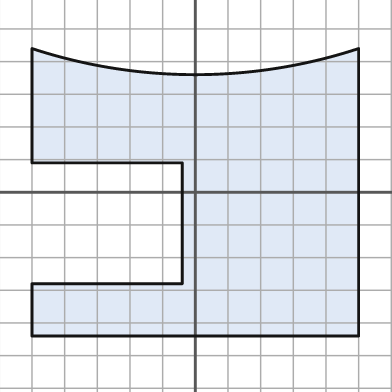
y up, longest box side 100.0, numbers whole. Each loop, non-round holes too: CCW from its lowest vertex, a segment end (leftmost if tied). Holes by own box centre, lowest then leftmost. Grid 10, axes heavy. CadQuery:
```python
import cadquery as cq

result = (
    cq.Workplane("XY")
    .moveTo(-50.0, -44.0)
    .lineTo(50.0, -44.0)
    .lineTo(50.0, 44.0)
    .threePointArc((0.0, 36.0), (-50.0, 44.0))
    .lineTo(-50.0, 9.0)
    .lineTo(-4.0, 9.0)
    .lineTo(-4.0, -28.0)
    .lineTo(-50.0, -28.0)
    .close()
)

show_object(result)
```